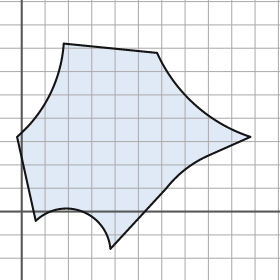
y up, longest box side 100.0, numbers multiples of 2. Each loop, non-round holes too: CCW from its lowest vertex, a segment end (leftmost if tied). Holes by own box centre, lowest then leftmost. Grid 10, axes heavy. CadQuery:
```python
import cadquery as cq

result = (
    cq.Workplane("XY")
    .moveTo(38.0, -16.0)
    .lineTo(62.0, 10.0)
    .threePointArc((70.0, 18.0), (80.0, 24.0))
    .lineTo(98.0, 32.0)
    .threePointArc((74.0, 46.0), (58.0, 68.0))
    .lineTo(18.0, 72.0)
    .threePointArc((12.0, 50.0), (-2.0, 32.0))
    .lineTo(6.0, -4.0)
    .threePointArc((26.0, 0.0), (38.0, -16.0))
    .close()
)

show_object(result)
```